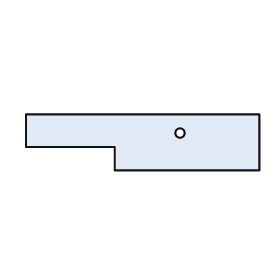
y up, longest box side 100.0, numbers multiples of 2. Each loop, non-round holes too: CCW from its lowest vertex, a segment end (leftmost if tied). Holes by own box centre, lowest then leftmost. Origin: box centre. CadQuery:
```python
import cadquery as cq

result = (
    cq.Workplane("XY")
    .moveTo(-12.0, -12.0)
    .lineTo(50.0, -12.0)
    .lineTo(50.0, 12.0)
    .lineTo(-50.0, 12.0)
    .lineTo(-50.0, -2.0)
    .lineTo(-12.0, -2.0)
    .close()
    .moveTo(16.0, 4.0)
    .circle(2.0)
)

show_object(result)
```